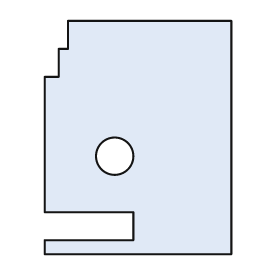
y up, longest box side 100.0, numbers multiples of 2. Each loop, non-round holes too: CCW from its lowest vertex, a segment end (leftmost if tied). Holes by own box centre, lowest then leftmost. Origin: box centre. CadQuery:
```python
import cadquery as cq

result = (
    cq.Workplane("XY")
    .moveTo(-40.0, -50.0)
    .lineTo(40.0, -50.0)
    .lineTo(40.0, 50.0)
    .lineTo(-30.0, 50.0)
    .lineTo(-30.0, 38.0)
    .lineTo(-34.0, 38.0)
    .lineTo(-34.0, 26.0)
    .lineTo(-40.0, 26.0)
    .lineTo(-40.0, -32.0)
    .lineTo(-2.0, -32.0)
    .lineTo(-2.0, -44.0)
    .lineTo(-40.0, -44.0)
    .close()
    .moveTo(-10.0, -8.0)
    .circle(8.0)
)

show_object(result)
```